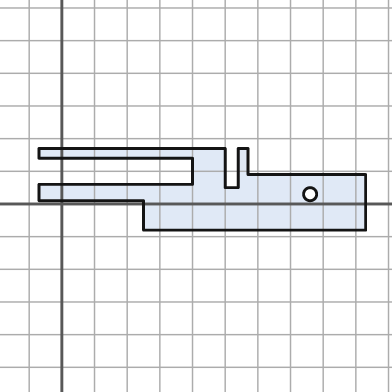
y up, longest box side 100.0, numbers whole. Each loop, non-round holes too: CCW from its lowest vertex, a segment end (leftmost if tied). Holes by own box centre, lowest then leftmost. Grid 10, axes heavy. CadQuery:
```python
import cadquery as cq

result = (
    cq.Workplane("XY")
    .moveTo(25.0, -8.0)
    .lineTo(93.0, -8.0)
    .lineTo(93.0, 9.0)
    .lineTo(57.0, 9.0)
    .lineTo(57.0, 17.0)
    .lineTo(54.0, 17.0)
    .lineTo(54.0, 5.0)
    .lineTo(50.0, 5.0)
    .lineTo(50.0, 17.0)
    .lineTo(-7.0, 17.0)
    .lineTo(-7.0, 14.0)
    .lineTo(40.0, 14.0)
    .lineTo(40.0, 6.0)
    .lineTo(-7.0, 6.0)
    .lineTo(-7.0, 1.0)
    .lineTo(25.0, 1.0)
    .close()
    .moveTo(76.0, 3.0)
    .circle(2.0)
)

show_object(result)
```